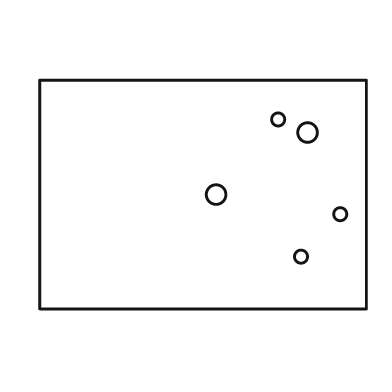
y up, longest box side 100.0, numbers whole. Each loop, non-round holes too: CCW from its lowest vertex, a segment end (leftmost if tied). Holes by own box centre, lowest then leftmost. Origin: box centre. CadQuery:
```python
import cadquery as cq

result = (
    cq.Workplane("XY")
    .moveTo(-50.0, -35.0)
    .lineTo(50.0, -35.0)
    .lineTo(50.0, 35.0)
    .lineTo(-50.0, 35.0)
    .close()
    .moveTo(30.0, -19.0)
    .circle(2.0)
    .moveTo(42.0, -6.0)
    .circle(2.0)
    .moveTo(4.0, 0.0)
    .circle(3.0)
    .moveTo(32.0, 19.0)
    .circle(3.0)
    .moveTo(23.0, 23.0)
    .circle(2.0)
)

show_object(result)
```